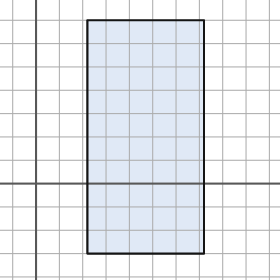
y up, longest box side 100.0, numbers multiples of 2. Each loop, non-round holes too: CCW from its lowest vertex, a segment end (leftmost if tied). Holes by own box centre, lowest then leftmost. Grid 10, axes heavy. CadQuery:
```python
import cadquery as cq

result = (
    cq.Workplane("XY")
    .moveTo(22.0, -30.0)
    .lineTo(72.0, -30.0)
    .lineTo(72.0, 70.0)
    .lineTo(22.0, 70.0)
    .close()
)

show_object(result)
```